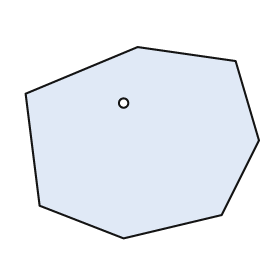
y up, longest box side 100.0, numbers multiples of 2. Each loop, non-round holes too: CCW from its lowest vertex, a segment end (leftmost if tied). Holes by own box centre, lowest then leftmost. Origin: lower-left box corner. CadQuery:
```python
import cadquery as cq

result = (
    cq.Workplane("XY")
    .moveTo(42.0, 0.0)
    .lineTo(84.0, 10.0)
    .lineTo(100.0, 42.0)
    .lineTo(90.0, 76.0)
    .lineTo(48.0, 82.0)
    .lineTo(0.0, 62.0)
    .lineTo(6.0, 14.0)
    .close()
    .moveTo(42.0, 58.0)
    .circle(2.0)
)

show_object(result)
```